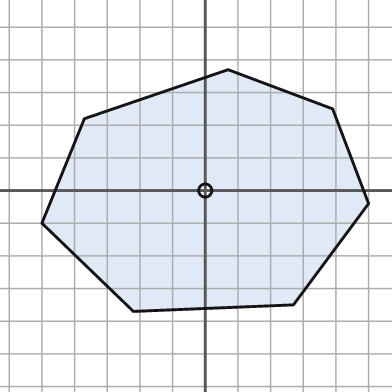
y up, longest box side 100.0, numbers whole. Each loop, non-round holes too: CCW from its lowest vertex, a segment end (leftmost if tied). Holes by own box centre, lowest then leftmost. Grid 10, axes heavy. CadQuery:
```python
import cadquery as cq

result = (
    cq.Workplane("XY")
    .moveTo(-22.0, -37.0)
    .lineTo(27.0, -35.0)
    .lineTo(50.0, -4.0)
    .lineTo(39.0, 25.0)
    .lineTo(7.0, 37.0)
    .lineTo(-37.0, 22.0)
    .lineTo(-50.0, -10.0)
    .close()
    .moveTo(0.0, 0.0)
    .circle(2.0)
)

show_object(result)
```